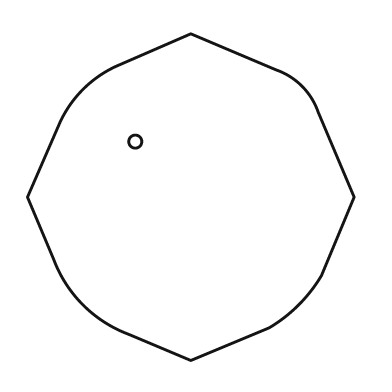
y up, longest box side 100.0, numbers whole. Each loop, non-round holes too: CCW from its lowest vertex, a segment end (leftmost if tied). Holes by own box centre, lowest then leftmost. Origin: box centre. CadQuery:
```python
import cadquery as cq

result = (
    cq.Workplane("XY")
    .moveTo(0.0, -50.0)
    .lineTo(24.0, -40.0)
    .threePointArc((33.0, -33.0), (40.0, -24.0))
    .lineTo(50.0, 0.0)
    .lineTo(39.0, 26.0)
    .threePointArc((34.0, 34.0), (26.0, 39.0))
    .lineTo(0.0, 50.0)
    .lineTo(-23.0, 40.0)
    .threePointArc((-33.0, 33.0), (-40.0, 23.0))
    .lineTo(-50.0, 0.0)
    .lineTo(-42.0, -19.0)
    .threePointArc((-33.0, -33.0), (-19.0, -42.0))
    .close()
    .moveTo(-17.0, 17.0)
    .circle(2.0)
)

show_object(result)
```